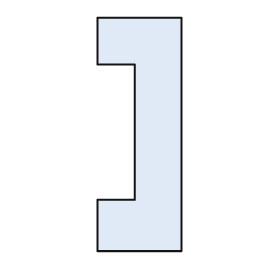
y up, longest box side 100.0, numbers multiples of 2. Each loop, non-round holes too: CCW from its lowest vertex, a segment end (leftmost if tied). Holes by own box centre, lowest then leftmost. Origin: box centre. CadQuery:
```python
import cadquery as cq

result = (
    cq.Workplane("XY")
    .moveTo(-18.0, -50.0)
    .lineTo(18.0, -50.0)
    .lineTo(18.0, 50.0)
    .lineTo(-18.0, 50.0)
    .lineTo(-18.0, 30.0)
    .lineTo(-2.0, 30.0)
    .lineTo(-2.0, -28.0)
    .lineTo(-18.0, -28.0)
    .close()
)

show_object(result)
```